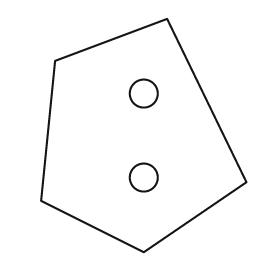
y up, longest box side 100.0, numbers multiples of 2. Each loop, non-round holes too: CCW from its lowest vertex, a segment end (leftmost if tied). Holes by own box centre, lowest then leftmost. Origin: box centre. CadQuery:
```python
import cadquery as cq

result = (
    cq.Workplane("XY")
    .moveTo(0.0, -50.0)
    .lineTo(44.0, -20.0)
    .lineTo(10.0, 50.0)
    .lineTo(-38.0, 32.0)
    .lineTo(-44.0, -28.0)
    .close()
    .moveTo(0.0, -18.0)
    .circle(6.0)
    .moveTo(0.0, 18.0)
    .circle(6.0)
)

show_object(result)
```